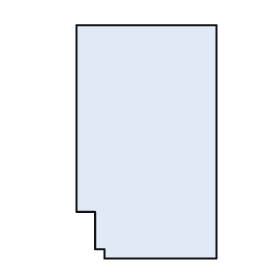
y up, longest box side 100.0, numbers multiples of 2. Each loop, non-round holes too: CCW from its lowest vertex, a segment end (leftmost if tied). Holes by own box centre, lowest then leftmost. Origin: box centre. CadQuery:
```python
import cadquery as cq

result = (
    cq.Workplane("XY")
    .moveTo(-18.0, -50.0)
    .lineTo(30.0, -50.0)
    .lineTo(30.0, 50.0)
    .lineTo(-30.0, 50.0)
    .lineTo(-30.0, -30.0)
    .lineTo(-22.0, -30.0)
    .lineTo(-22.0, -46.0)
    .lineTo(-18.0, -46.0)
    .close()
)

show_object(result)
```